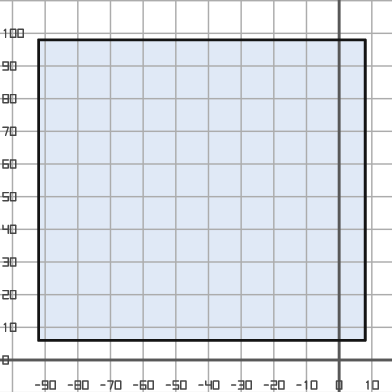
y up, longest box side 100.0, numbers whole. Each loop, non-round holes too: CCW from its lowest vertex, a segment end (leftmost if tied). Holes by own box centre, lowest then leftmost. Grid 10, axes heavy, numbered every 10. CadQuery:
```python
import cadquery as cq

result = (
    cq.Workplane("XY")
    .moveTo(-92.0, 6.0)
    .lineTo(8.0, 6.0)
    .lineTo(8.0, 98.0)
    .lineTo(-92.0, 98.0)
    .close()
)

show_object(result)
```